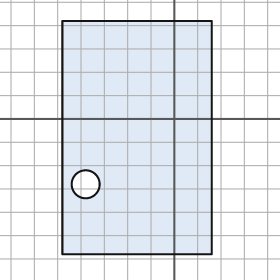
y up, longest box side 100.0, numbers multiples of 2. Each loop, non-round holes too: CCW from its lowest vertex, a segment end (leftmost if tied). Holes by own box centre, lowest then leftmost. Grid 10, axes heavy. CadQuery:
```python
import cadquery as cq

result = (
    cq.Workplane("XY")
    .moveTo(-48.0, -58.0)
    .lineTo(16.0, -58.0)
    .lineTo(16.0, 42.0)
    .lineTo(-48.0, 42.0)
    .close()
    .moveTo(-38.0, -28.0)
    .circle(6.0)
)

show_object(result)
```